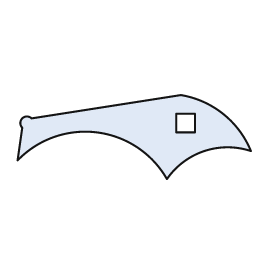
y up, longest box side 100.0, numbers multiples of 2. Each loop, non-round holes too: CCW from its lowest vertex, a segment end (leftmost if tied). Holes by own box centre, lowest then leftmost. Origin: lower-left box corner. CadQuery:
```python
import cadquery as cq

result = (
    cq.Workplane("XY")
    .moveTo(64.0, 0.0)
    .threePointArc((80.0, 12.0), (100.0, 12.0))
    .threePointArc((88.0, 28.0), (70.0, 36.0))
    .lineTo(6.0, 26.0)
    .threePointArc((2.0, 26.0), (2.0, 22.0))
    .lineTo(0.0, 8.0)
    .threePointArc((34.0, 20.0), (64.0, 0.0))
    .close()
    .moveTo(68.0, 20.0)
    .lineTo(76.0, 20.0)
    .lineTo(76.0, 28.0)
    .lineTo(68.0, 28.0)
    .close()
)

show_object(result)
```